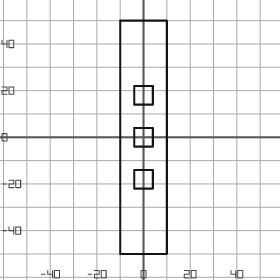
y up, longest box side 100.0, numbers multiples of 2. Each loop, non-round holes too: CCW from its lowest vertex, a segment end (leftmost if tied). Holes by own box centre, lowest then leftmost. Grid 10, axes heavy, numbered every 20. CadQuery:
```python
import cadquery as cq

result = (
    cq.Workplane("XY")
    .moveTo(-10.0, -50.0)
    .lineTo(10.0, -50.0)
    .lineTo(10.0, 50.0)
    .lineTo(-10.0, 50.0)
    .close()
    .moveTo(-4.0, -22.0)
    .lineTo(4.0, -22.0)
    .lineTo(4.0, -14.0)
    .lineTo(-4.0, -14.0)
    .close()
    .moveTo(-4.0, -4.0)
    .lineTo(4.0, -4.0)
    .lineTo(4.0, 4.0)
    .lineTo(-4.0, 4.0)
    .close()
    .moveTo(-4.0, 14.0)
    .lineTo(4.0, 14.0)
    .lineTo(4.0, 22.0)
    .lineTo(-4.0, 22.0)
    .close()
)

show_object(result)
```